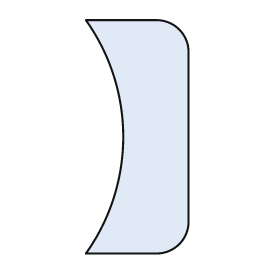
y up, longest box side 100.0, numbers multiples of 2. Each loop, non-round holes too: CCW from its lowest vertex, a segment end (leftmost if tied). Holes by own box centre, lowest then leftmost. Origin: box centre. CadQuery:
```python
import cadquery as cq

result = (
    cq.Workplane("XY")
    .moveTo(-22.0, -50.0)
    .lineTo(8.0, -50.0)
    .threePointArc((18.0, -46.0), (22.0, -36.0))
    .lineTo(22.0, 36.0)
    .threePointArc((18.0, 46.0), (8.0, 50.0))
    .lineTo(-22.0, 50.0)
    .threePointArc((-6.0, 0.0), (-22.0, -50.0))
    .close()
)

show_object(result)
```